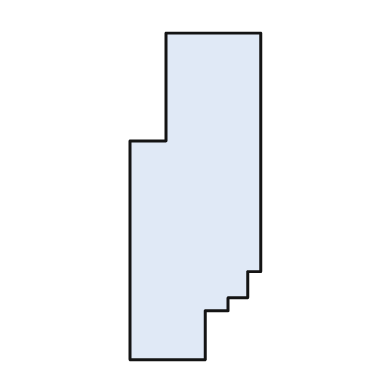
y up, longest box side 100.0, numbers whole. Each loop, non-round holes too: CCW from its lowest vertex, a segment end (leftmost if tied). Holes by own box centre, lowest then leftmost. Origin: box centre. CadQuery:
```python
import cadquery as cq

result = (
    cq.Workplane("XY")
    .moveTo(-20.0, -50.0)
    .lineTo(3.0, -50.0)
    .lineTo(3.0, -35.0)
    .lineTo(10.0, -35.0)
    .lineTo(10.0, -31.0)
    .lineTo(16.0, -31.0)
    .lineTo(16.0, -23.0)
    .lineTo(20.0, -23.0)
    .lineTo(20.0, 50.0)
    .lineTo(-9.0, 50.0)
    .lineTo(-9.0, 17.0)
    .lineTo(-20.0, 17.0)
    .close()
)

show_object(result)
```